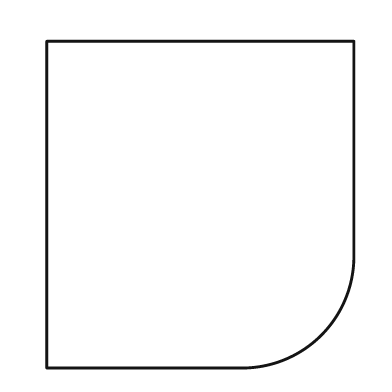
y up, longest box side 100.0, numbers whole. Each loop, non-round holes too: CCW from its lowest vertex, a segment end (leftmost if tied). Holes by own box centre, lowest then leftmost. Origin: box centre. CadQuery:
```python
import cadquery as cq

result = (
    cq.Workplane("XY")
    .moveTo(-47.0, -50.0)
    .lineTo(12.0, -50.0)
    .threePointArc((37.0, -40.0), (47.0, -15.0))
    .lineTo(47.0, 50.0)
    .lineTo(-47.0, 50.0)
    .close()
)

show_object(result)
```